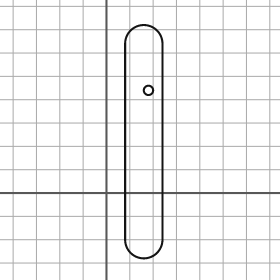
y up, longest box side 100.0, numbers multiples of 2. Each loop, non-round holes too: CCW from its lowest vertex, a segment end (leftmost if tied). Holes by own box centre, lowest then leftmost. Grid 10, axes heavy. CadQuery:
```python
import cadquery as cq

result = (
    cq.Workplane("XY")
    .moveTo(8.0, -20.0)
    .threePointArc((16.0, -28.0), (24.0, -20.0))
    .lineTo(24.0, 64.0)
    .threePointArc((16.0, 72.0), (8.0, 64.0))
    .close()
    .moveTo(18.0, 44.0)
    .circle(2.0)
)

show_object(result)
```